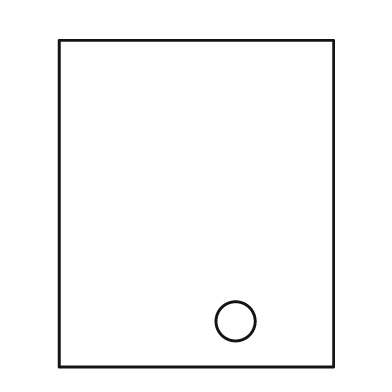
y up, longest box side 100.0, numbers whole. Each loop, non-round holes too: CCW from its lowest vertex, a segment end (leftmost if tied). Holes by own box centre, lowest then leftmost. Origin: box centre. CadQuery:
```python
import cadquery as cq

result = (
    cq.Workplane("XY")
    .moveTo(-42.0, -50.0)
    .lineTo(42.0, -50.0)
    .lineTo(42.0, 50.0)
    .lineTo(-42.0, 50.0)
    .close()
    .moveTo(12.0, -36.0)
    .circle(6.0)
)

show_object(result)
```